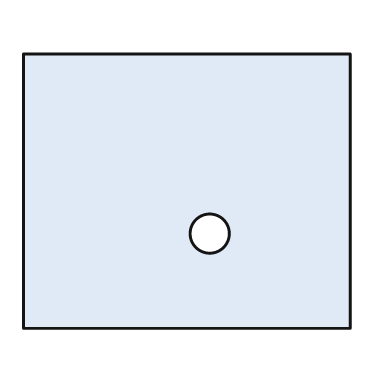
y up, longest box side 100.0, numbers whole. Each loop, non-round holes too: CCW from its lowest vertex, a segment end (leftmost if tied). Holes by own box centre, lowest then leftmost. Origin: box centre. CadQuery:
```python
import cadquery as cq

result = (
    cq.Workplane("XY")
    .moveTo(-50.0, -42.0)
    .lineTo(50.0, -42.0)
    .lineTo(50.0, 42.0)
    .lineTo(-50.0, 42.0)
    .close()
    .moveTo(7.0, -13.0)
    .circle(6.0)
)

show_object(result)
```